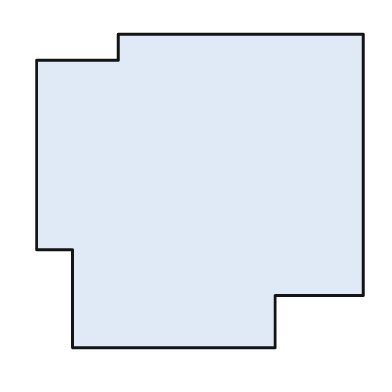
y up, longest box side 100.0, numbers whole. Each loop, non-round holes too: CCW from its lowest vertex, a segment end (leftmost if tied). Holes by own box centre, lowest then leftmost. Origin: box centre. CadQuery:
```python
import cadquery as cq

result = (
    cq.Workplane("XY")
    .moveTo(-39.0, -48.0)
    .lineTo(23.0, -48.0)
    .lineTo(23.0, -32.0)
    .lineTo(50.0, -32.0)
    .lineTo(50.0, 48.0)
    .lineTo(-25.0, 48.0)
    .lineTo(-25.0, 40.0)
    .lineTo(-50.0, 40.0)
    .lineTo(-50.0, -18.0)
    .lineTo(-39.0, -18.0)
    .close()
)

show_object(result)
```